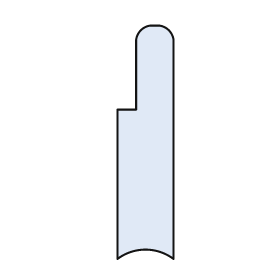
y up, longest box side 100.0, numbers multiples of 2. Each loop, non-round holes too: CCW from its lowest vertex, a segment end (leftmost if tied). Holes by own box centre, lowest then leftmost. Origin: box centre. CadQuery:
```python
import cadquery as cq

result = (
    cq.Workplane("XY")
    .moveTo(-12.0, -50.0)
    .threePointArc((0.0, -46.0), (12.0, -50.0))
    .lineTo(12.0, 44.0)
    .threePointArc((10.0, 48.0), (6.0, 50.0))
    .lineTo(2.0, 50.0)
    .threePointArc((-2.0, 48.0), (-4.0, 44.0))
    .lineTo(-4.0, 14.0)
    .lineTo(-12.0, 14.0)
    .close()
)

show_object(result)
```